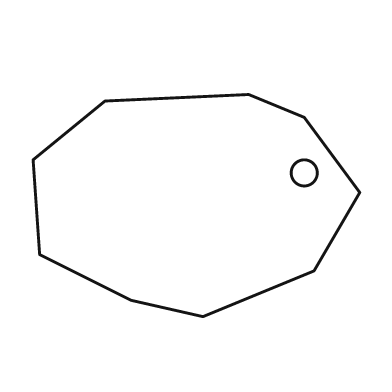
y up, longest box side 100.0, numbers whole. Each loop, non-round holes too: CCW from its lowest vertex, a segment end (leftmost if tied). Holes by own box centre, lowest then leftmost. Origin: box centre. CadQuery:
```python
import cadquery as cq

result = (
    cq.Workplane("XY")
    .moveTo(2.0, -34.0)
    .lineTo(36.0, -20.0)
    .lineTo(50.0, 4.0)
    .lineTo(33.0, 27.0)
    .lineTo(16.0, 34.0)
    .lineTo(-28.0, 32.0)
    .lineTo(-50.0, 14.0)
    .lineTo(-48.0, -15.0)
    .lineTo(-20.0, -29.0)
    .close()
    .moveTo(33.0, 10.0)
    .circle(4.0)
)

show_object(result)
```